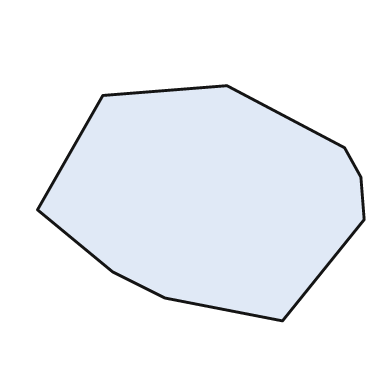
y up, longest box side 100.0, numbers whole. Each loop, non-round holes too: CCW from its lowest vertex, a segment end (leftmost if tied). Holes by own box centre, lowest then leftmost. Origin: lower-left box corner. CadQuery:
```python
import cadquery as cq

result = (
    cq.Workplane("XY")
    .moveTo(75.0, 0.0)
    .lineTo(100.0, 31.0)
    .lineTo(99.0, 44.0)
    .lineTo(94.0, 53.0)
    .lineTo(58.0, 72.0)
    .lineTo(20.0, 69.0)
    .lineTo(0.0, 34.0)
    .lineTo(23.0, 15.0)
    .lineTo(39.0, 7.0)
    .close()
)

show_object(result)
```